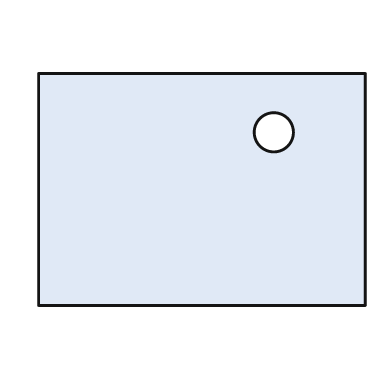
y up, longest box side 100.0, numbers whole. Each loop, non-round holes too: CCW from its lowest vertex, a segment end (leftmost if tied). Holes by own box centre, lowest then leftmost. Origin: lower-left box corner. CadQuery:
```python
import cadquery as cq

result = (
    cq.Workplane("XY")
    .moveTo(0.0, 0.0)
    .lineTo(100.0, 0.0)
    .lineTo(100.0, 71.0)
    .lineTo(0.0, 71.0)
    .close()
    .moveTo(72.0, 53.0)
    .circle(6.0)
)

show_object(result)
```